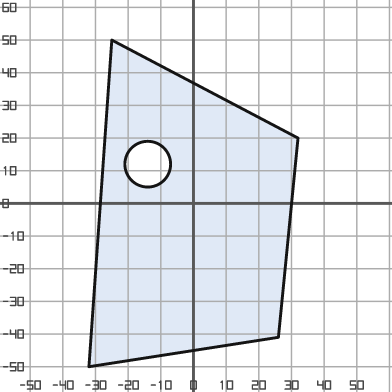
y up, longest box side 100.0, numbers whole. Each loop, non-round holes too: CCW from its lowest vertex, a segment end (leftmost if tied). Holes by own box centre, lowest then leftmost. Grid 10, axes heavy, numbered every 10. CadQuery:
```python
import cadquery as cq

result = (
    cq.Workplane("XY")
    .moveTo(-32.0, -50.0)
    .lineTo(26.0, -41.0)
    .lineTo(32.0, 20.0)
    .lineTo(-25.0, 50.0)
    .close()
    .moveTo(-14.0, 12.0)
    .circle(7.0)
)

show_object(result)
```